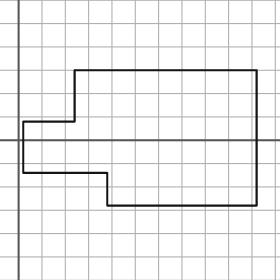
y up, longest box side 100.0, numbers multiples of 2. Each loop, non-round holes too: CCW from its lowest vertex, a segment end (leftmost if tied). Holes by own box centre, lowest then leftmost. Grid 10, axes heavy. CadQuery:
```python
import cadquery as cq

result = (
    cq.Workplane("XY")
    .moveTo(38.0, -28.0)
    .lineTo(102.0, -28.0)
    .lineTo(102.0, 30.0)
    .lineTo(24.0, 30.0)
    .lineTo(24.0, 8.0)
    .lineTo(2.0, 8.0)
    .lineTo(2.0, -14.0)
    .lineTo(38.0, -14.0)
    .close()
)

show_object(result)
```